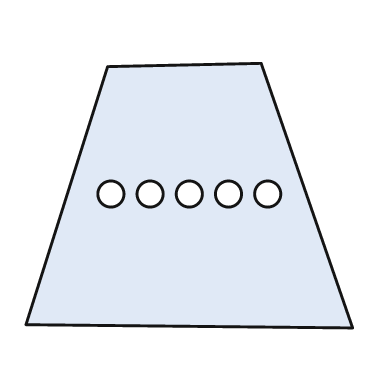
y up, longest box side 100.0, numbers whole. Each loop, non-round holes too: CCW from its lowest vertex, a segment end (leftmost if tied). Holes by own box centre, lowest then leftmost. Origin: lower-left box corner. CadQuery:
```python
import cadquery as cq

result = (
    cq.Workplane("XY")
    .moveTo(100.0, 0.0)
    .lineTo(72.0, 81.0)
    .lineTo(25.0, 80.0)
    .lineTo(0.0, 1.0)
    .close()
    .moveTo(26.0, 41.0)
    .circle(4.0)
    .moveTo(38.0, 41.0)
    .circle(4.0)
    .moveTo(50.0, 41.0)
    .circle(4.0)
    .moveTo(62.0, 41.0)
    .circle(4.0)
    .moveTo(74.0, 41.0)
    .circle(4.0)
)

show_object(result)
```